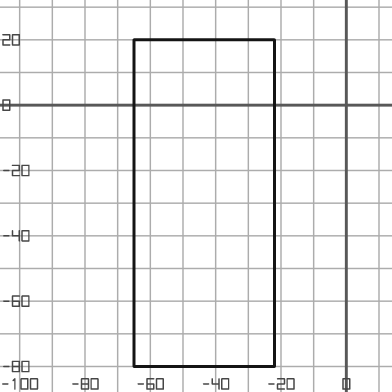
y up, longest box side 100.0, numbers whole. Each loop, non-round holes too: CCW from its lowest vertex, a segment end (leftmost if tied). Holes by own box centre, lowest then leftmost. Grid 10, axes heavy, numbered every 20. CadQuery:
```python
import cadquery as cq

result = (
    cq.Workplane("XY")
    .moveTo(-65.0, -80.0)
    .lineTo(-22.0, -80.0)
    .lineTo(-22.0, 20.0)
    .lineTo(-65.0, 20.0)
    .close()
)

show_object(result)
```